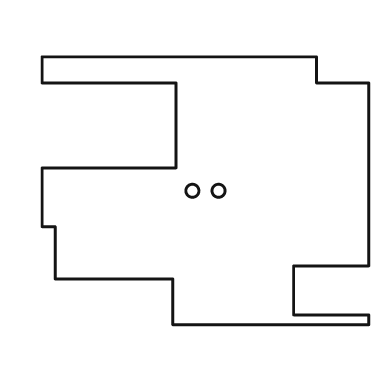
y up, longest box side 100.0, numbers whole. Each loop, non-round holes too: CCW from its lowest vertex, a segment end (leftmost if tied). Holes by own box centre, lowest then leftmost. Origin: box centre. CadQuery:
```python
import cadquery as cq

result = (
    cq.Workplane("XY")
    .moveTo(-10.0, -41.0)
    .lineTo(50.0, -41.0)
    .lineTo(50.0, -38.0)
    .lineTo(27.0, -38.0)
    .lineTo(27.0, -23.0)
    .lineTo(50.0, -23.0)
    .lineTo(50.0, 33.0)
    .lineTo(34.0, 33.0)
    .lineTo(34.0, 41.0)
    .lineTo(-50.0, 41.0)
    .lineTo(-50.0, 33.0)
    .lineTo(-9.0, 33.0)
    .lineTo(-9.0, 7.0)
    .lineTo(-50.0, 7.0)
    .lineTo(-50.0, -11.0)
    .lineTo(-46.0, -11.0)
    .lineTo(-46.0, -27.0)
    .lineTo(-10.0, -27.0)
    .close()
    .moveTo(-4.0, 0.0)
    .circle(2.0)
    .moveTo(4.0, 0.0)
    .circle(2.0)
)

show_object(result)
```